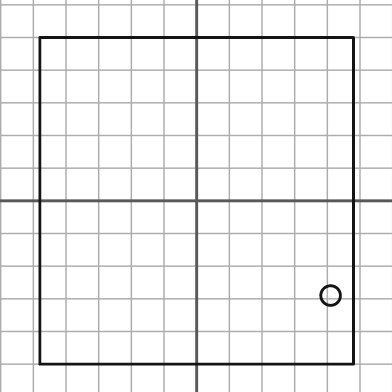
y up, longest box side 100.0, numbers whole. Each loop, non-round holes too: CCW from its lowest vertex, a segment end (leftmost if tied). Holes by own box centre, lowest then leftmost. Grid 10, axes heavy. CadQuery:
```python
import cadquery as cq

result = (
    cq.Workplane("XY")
    .moveTo(-48.0, -50.0)
    .lineTo(48.0, -50.0)
    .lineTo(48.0, 50.0)
    .lineTo(-48.0, 50.0)
    .close()
    .moveTo(41.0, -29.0)
    .circle(3.0)
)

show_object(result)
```